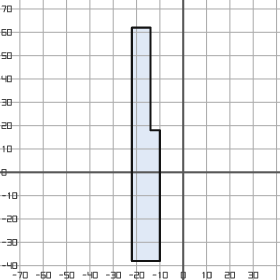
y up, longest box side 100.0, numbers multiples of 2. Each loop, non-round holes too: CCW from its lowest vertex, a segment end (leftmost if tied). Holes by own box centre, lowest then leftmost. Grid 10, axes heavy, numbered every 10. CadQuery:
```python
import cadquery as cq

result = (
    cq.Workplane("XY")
    .moveTo(-22.0, -38.0)
    .lineTo(-10.0, -38.0)
    .lineTo(-10.0, 18.0)
    .lineTo(-14.0, 18.0)
    .lineTo(-14.0, 62.0)
    .lineTo(-22.0, 62.0)
    .close()
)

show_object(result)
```